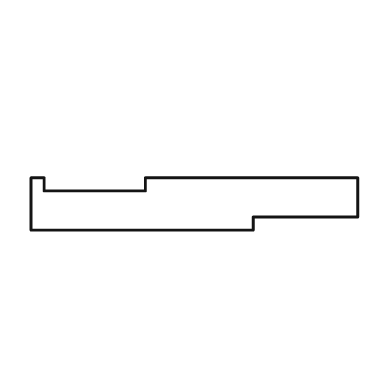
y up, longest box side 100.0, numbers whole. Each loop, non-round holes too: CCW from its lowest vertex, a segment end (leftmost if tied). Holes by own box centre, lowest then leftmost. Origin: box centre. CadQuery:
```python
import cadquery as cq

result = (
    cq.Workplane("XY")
    .moveTo(-50.0, -8.0)
    .lineTo(18.0, -8.0)
    .lineTo(18.0, -4.0)
    .lineTo(50.0, -4.0)
    .lineTo(50.0, 8.0)
    .lineTo(-15.0, 8.0)
    .lineTo(-15.0, 4.0)
    .lineTo(-46.0, 4.0)
    .lineTo(-46.0, 8.0)
    .lineTo(-50.0, 8.0)
    .close()
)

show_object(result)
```